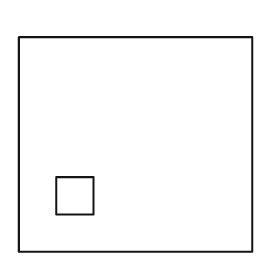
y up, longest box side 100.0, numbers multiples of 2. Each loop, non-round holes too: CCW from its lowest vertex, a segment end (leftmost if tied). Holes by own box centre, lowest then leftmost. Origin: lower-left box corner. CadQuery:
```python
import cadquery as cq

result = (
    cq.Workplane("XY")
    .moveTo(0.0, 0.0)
    .lineTo(100.0, 0.0)
    .lineTo(100.0, 92.0)
    .lineTo(0.0, 92.0)
    .close()
    .moveTo(16.0, 16.0)
    .lineTo(32.0, 16.0)
    .lineTo(32.0, 32.0)
    .lineTo(16.0, 32.0)
    .close()
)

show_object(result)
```